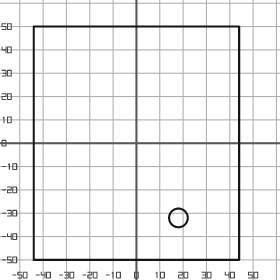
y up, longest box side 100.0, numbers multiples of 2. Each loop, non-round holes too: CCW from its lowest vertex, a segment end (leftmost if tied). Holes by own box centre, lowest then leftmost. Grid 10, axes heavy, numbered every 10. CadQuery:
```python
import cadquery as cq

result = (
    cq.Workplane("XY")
    .moveTo(-44.0, -50.0)
    .lineTo(44.0, -50.0)
    .lineTo(44.0, 50.0)
    .lineTo(-44.0, 50.0)
    .close()
    .moveTo(18.0, -32.0)
    .circle(4.0)
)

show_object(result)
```